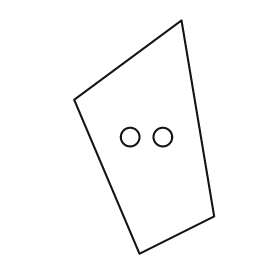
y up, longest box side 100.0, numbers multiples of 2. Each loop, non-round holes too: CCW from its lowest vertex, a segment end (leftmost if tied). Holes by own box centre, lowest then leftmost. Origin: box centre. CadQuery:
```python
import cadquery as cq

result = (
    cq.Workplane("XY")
    .moveTo(-2.0, -50.0)
    .lineTo(30.0, -34.0)
    .lineTo(16.0, 50.0)
    .lineTo(-30.0, 16.0)
    .close()
    .moveTo(-6.0, 0.0)
    .circle(4.0)
    .moveTo(8.0, 0.0)
    .circle(4.0)
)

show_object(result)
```